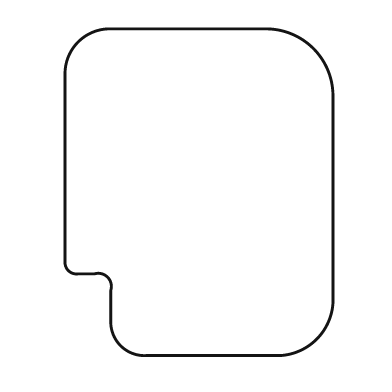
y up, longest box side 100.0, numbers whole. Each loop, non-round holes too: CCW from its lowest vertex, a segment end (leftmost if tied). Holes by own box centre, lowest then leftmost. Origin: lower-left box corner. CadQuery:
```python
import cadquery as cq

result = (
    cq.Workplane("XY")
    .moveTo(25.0, 0.0)
    .lineTo(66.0, 0.0)
    .threePointArc((77.0, 5.0), (82.0, 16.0))
    .lineTo(82.0, 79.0)
    .threePointArc((76.0, 94.0), (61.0, 100.0))
    .lineTo(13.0, 100.0)
    .threePointArc((4.0, 96.0), (0.0, 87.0))
    .lineTo(0.0, 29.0)
    .threePointArc((1.0, 26.0), (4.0, 25.0))
    .lineTo(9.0, 25.0)
    .threePointArc((13.0, 24.0), (14.0, 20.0))
    .lineTo(14.0, 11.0)
    .threePointArc((17.0, 3.0), (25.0, 0.0))
    .close()
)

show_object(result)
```